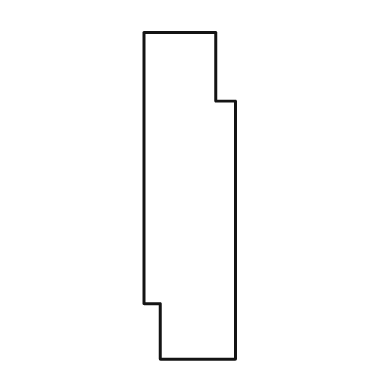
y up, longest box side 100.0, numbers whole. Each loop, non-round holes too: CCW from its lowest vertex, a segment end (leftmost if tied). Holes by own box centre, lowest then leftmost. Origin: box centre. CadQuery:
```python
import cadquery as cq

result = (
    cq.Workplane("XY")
    .moveTo(-9.0, -50.0)
    .lineTo(14.0, -50.0)
    .lineTo(14.0, 29.0)
    .lineTo(8.0, 29.0)
    .lineTo(8.0, 50.0)
    .lineTo(-14.0, 50.0)
    .lineTo(-14.0, -33.0)
    .lineTo(-9.0, -33.0)
    .close()
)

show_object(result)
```